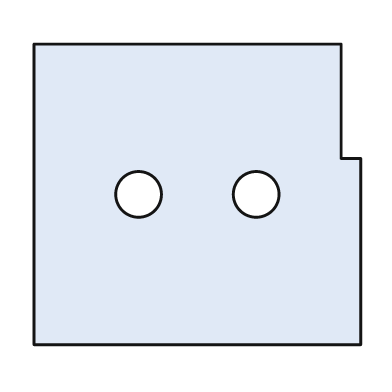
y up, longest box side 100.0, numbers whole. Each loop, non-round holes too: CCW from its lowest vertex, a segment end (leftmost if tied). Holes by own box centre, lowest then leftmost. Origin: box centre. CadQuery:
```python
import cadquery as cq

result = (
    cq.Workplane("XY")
    .moveTo(-50.0, -46.0)
    .lineTo(50.0, -46.0)
    .lineTo(50.0, 11.0)
    .lineTo(44.0, 11.0)
    .lineTo(44.0, 46.0)
    .lineTo(-50.0, 46.0)
    .close()
    .moveTo(-18.0, 0.0)
    .circle(7.0)
    .moveTo(18.0, 0.0)
    .circle(7.0)
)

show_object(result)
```